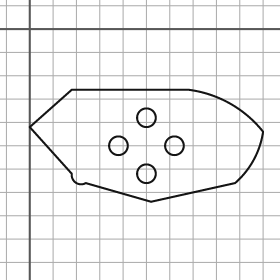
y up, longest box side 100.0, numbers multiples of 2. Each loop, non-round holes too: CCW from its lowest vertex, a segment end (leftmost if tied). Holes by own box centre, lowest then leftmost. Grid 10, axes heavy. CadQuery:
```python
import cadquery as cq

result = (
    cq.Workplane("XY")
    .moveTo(52.0, -74.0)
    .lineTo(88.0, -66.0)
    .threePointArc((96.0, -56.0), (100.0, -44.0))
    .threePointArc((86.0, -32.0), (68.0, -26.0))
    .lineTo(18.0, -26.0)
    .lineTo(0.0, -42.0)
    .lineTo(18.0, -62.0)
    .threePointArc((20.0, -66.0), (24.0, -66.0))
    .close()
    .moveTo(50.0, -62.0)
    .circle(4.0)
    .moveTo(38.0, -50.0)
    .circle(4.0)
    .moveTo(62.0, -50.0)
    .circle(4.0)
    .moveTo(50.0, -38.0)
    .circle(4.0)
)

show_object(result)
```